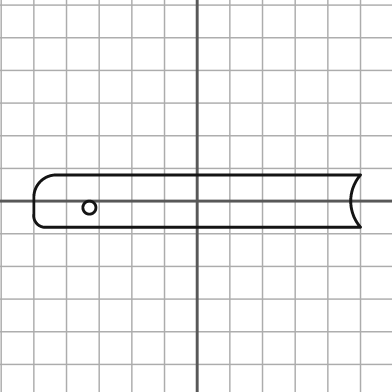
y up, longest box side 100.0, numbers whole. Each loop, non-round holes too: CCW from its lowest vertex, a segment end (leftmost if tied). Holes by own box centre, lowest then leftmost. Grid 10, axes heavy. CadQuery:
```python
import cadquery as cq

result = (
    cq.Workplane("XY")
    .moveTo(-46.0, -8.0)
    .lineTo(50.0, -8.0)
    .threePointArc((47.0, 0.0), (50.0, 8.0))
    .lineTo(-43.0, 8.0)
    .threePointArc((-48.0, 6.0), (-50.0, 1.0))
    .lineTo(-50.0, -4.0)
    .threePointArc((-49.0, -7.0), (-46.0, -8.0))
    .close()
    .moveTo(-33.0, -2.0)
    .circle(2.0)
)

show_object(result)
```